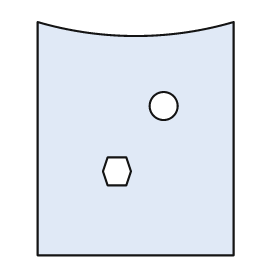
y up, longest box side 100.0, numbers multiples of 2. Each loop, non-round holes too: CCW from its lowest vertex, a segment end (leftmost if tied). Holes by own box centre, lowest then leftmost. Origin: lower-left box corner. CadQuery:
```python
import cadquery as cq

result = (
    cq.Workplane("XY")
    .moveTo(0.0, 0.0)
    .lineTo(84.0, 0.0)
    .lineTo(84.0, 100.0)
    .threePointArc((42.0, 94.0), (0.0, 100.0))
    .close()
    .moveTo(30.0, 30.0)
    .lineTo(38.0, 30.0)
    .lineTo(40.0, 36.0)
    .lineTo(38.0, 42.0)
    .lineTo(30.0, 42.0)
    .lineTo(28.0, 36.0)
    .close()
    .moveTo(54.0, 64.0)
    .circle(6.0)
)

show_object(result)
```